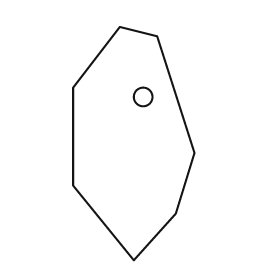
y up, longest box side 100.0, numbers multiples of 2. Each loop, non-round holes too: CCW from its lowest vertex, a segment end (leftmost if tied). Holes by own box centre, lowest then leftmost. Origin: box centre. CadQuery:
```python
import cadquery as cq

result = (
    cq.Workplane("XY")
    .moveTo(0.0, -50.0)
    .lineTo(18.0, -30.0)
    .lineTo(26.0, -4.0)
    .lineTo(10.0, 46.0)
    .lineTo(-6.0, 50.0)
    .lineTo(-26.0, 24.0)
    .lineTo(-26.0, -18.0)
    .close()
    .moveTo(4.0, 20.0)
    .circle(4.0)
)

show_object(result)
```